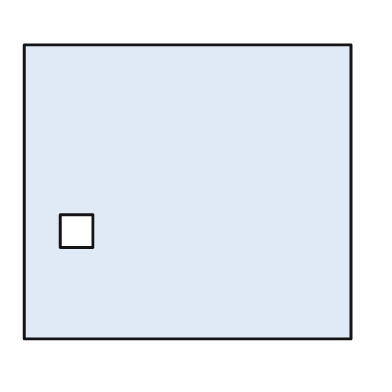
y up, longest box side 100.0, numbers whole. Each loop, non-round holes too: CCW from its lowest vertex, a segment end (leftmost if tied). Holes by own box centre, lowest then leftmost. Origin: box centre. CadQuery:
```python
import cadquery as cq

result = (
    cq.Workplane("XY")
    .moveTo(-50.0, -45.0)
    .lineTo(50.0, -45.0)
    .lineTo(50.0, 45.0)
    .lineTo(-50.0, 45.0)
    .close()
    .moveTo(-39.0, -17.0)
    .lineTo(-29.0, -17.0)
    .lineTo(-29.0, -7.0)
    .lineTo(-39.0, -7.0)
    .close()
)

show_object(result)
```